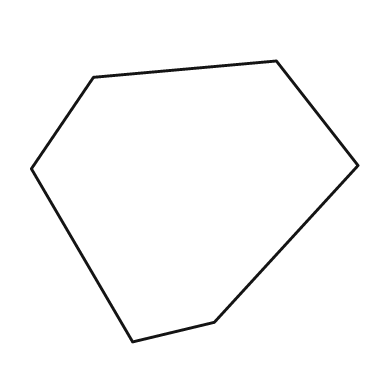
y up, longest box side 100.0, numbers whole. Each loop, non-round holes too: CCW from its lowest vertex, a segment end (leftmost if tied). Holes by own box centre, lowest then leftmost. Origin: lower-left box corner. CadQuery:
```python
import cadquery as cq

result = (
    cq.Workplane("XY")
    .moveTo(31.0, 0.0)
    .lineTo(56.0, 6.0)
    .lineTo(100.0, 54.0)
    .lineTo(75.0, 86.0)
    .lineTo(19.0, 81.0)
    .lineTo(0.0, 53.0)
    .close()
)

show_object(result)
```